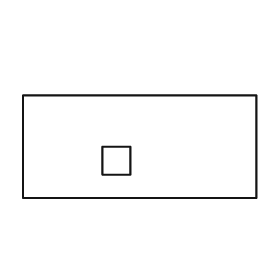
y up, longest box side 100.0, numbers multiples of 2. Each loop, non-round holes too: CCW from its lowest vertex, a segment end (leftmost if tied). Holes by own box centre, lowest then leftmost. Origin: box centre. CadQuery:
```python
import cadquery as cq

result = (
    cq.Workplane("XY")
    .moveTo(-50.0, -22.0)
    .lineTo(50.0, -22.0)
    .lineTo(50.0, 22.0)
    .lineTo(-50.0, 22.0)
    .close()
    .moveTo(-16.0, -12.0)
    .lineTo(-4.0, -12.0)
    .lineTo(-4.0, 0.0)
    .lineTo(-16.0, 0.0)
    .close()
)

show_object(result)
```